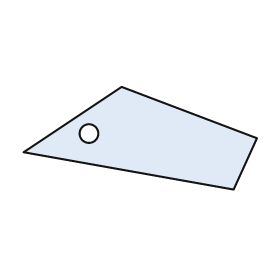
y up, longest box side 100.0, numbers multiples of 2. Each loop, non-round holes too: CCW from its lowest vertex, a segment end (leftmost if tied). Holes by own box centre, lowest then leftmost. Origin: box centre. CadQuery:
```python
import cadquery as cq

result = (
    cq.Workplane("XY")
    .moveTo(40.0, -22.0)
    .lineTo(50.0, 0.0)
    .lineTo(-8.0, 22.0)
    .lineTo(-50.0, -6.0)
    .close()
    .moveTo(-22.0, 2.0)
    .circle(4.0)
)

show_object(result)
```